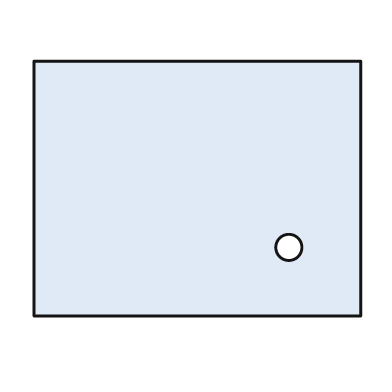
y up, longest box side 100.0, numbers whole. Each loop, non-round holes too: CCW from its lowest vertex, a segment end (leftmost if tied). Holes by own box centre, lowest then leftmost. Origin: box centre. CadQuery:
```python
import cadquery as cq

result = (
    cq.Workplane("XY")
    .moveTo(-50.0, -39.0)
    .lineTo(50.0, -39.0)
    .lineTo(50.0, 39.0)
    .lineTo(-50.0, 39.0)
    .close()
    .moveTo(28.0, -18.0)
    .circle(4.0)
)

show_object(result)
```